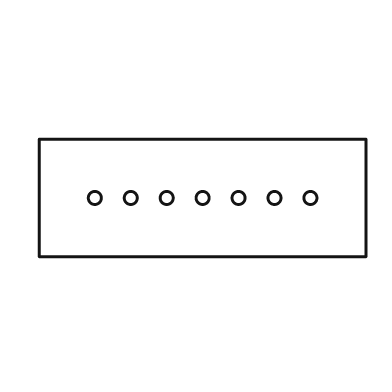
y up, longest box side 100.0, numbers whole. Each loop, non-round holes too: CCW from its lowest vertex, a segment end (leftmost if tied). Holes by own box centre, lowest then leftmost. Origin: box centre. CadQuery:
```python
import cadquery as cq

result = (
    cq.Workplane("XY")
    .moveTo(-50.0, -18.0)
    .lineTo(50.0, -18.0)
    .lineTo(50.0, 18.0)
    .lineTo(-50.0, 18.0)
    .close()
    .moveTo(-33.0, 0.0)
    .circle(2.0)
    .moveTo(-22.0, 0.0)
    .circle(2.0)
    .moveTo(-11.0, 0.0)
    .circle(2.0)
    .moveTo(0.0, 0.0)
    .circle(2.0)
    .moveTo(11.0, 0.0)
    .circle(2.0)
    .moveTo(22.0, 0.0)
    .circle(2.0)
    .moveTo(33.0, 0.0)
    .circle(2.0)
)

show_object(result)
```